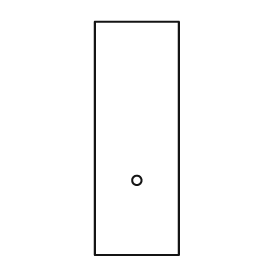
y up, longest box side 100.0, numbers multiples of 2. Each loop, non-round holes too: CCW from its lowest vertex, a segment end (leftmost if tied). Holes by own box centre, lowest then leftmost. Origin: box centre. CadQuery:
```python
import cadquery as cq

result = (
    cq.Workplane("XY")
    .moveTo(-18.0, -50.0)
    .lineTo(18.0, -50.0)
    .lineTo(18.0, 50.0)
    .lineTo(-18.0, 50.0)
    .close()
    .moveTo(0.0, -18.0)
    .circle(2.0)
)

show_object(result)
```